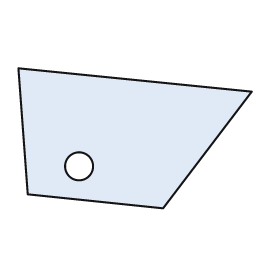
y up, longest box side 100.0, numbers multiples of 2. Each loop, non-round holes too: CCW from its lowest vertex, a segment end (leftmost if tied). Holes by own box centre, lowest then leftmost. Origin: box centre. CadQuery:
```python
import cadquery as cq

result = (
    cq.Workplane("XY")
    .moveTo(12.0, -30.0)
    .lineTo(50.0, 20.0)
    .lineTo(-50.0, 30.0)
    .lineTo(-46.0, -24.0)
    .close()
    .moveTo(-24.0, -12.0)
    .circle(6.0)
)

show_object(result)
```